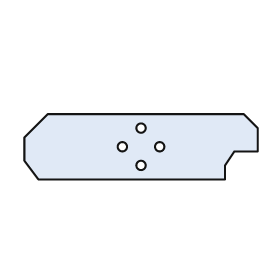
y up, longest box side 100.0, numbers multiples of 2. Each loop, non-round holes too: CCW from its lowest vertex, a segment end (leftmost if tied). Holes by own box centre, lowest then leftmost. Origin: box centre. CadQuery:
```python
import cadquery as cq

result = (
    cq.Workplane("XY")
    .moveTo(-44.0, -14.0)
    .lineTo(36.0, -14.0)
    .lineTo(36.0, -8.0)
    .lineTo(40.0, -2.0)
    .lineTo(50.0, -2.0)
    .lineTo(50.0, 8.0)
    .lineTo(44.0, 14.0)
    .lineTo(-40.0, 14.0)
    .lineTo(-50.0, 4.0)
    .lineTo(-50.0, -6.0)
    .close()
    .moveTo(0.0, -8.0)
    .circle(2.0)
    .moveTo(-8.0, 0.0)
    .circle(2.0)
    .moveTo(8.0, 0.0)
    .circle(2.0)
    .moveTo(0.0, 8.0)
    .circle(2.0)
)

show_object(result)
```